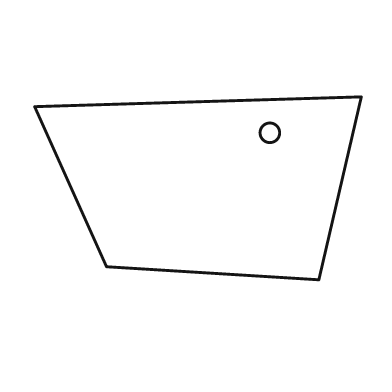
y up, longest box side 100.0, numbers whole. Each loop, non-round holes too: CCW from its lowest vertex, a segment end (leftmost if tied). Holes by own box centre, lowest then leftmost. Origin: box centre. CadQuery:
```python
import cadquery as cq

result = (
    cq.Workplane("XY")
    .moveTo(37.0, -28.0)
    .lineTo(50.0, 28.0)
    .lineTo(-50.0, 25.0)
    .lineTo(-28.0, -24.0)
    .close()
    .moveTo(22.0, 17.0)
    .circle(3.0)
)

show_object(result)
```